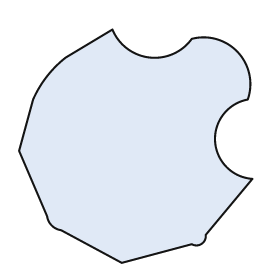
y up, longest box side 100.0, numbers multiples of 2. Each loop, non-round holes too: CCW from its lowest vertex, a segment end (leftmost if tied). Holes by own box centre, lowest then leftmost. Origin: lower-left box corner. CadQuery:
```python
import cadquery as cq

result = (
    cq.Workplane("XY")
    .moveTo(44.0, 0.0)
    .lineTo(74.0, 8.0)
    .threePointArc((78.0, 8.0), (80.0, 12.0))
    .lineTo(100.0, 36.0)
    .threePointArc((84.0, 52.0), (98.0, 70.0))
    .threePointArc((94.0, 90.0), (74.0, 96.0))
    .threePointArc((56.0, 88.0), (40.0, 100.0))
    .lineTo(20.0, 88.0)
    .threePointArc((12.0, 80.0), (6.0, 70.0))
    .lineTo(0.0, 48.0)
    .lineTo(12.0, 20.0)
    .threePointArc((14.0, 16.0), (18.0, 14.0))
    .close()
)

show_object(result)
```